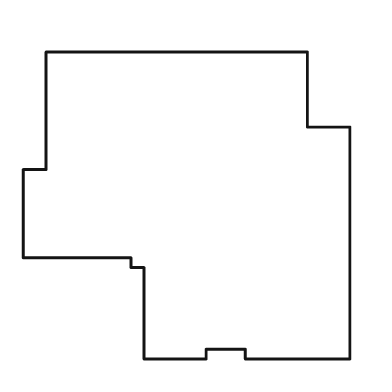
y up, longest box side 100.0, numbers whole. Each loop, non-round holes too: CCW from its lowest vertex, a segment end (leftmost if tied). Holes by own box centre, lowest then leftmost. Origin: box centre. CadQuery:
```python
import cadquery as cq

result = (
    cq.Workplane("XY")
    .moveTo(-13.0, -47.0)
    .lineTo(6.0, -47.0)
    .lineTo(6.0, -44.0)
    .lineTo(18.0, -44.0)
    .lineTo(18.0, -47.0)
    .lineTo(50.0, -47.0)
    .lineTo(50.0, 24.0)
    .lineTo(37.0, 24.0)
    .lineTo(37.0, 47.0)
    .lineTo(-43.0, 47.0)
    .lineTo(-43.0, 11.0)
    .lineTo(-50.0, 11.0)
    .lineTo(-50.0, -16.0)
    .lineTo(-17.0, -16.0)
    .lineTo(-17.0, -19.0)
    .lineTo(-13.0, -19.0)
    .close()
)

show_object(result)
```